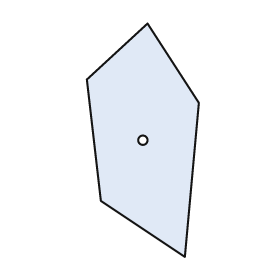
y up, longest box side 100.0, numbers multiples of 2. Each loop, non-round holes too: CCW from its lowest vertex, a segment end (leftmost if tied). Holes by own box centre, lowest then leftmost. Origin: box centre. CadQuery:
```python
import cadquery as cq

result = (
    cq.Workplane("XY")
    .moveTo(18.0, -50.0)
    .lineTo(24.0, 16.0)
    .lineTo(2.0, 50.0)
    .lineTo(-24.0, 26.0)
    .lineTo(-18.0, -26.0)
    .close()
    .moveTo(0.0, 0.0)
    .circle(2.0)
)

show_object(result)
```